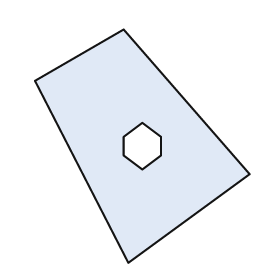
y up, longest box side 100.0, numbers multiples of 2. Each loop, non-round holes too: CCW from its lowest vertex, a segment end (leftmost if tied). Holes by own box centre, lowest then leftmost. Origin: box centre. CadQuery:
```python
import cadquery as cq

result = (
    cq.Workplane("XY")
    .moveTo(-6.0, -50.0)
    .lineTo(46.0, -12.0)
    .lineTo(-8.0, 50.0)
    .lineTo(-46.0, 28.0)
    .close()
    .moveTo(0.0, -10.0)
    .lineTo(8.0, -4.0)
    .lineTo(8.0, 4.0)
    .lineTo(0.0, 10.0)
    .lineTo(-8.0, 4.0)
    .lineTo(-8.0, -4.0)
    .close()
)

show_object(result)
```